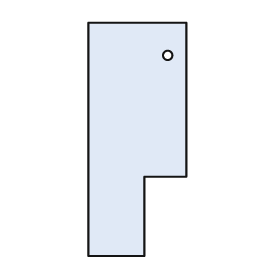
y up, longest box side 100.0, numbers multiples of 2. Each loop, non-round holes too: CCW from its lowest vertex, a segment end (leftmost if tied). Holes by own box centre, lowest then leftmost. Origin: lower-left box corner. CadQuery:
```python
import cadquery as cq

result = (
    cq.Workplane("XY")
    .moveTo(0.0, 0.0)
    .lineTo(24.0, 0.0)
    .lineTo(24.0, 34.0)
    .lineTo(42.0, 34.0)
    .lineTo(42.0, 100.0)
    .lineTo(0.0, 100.0)
    .close()
    .moveTo(34.0, 86.0)
    .circle(2.0)
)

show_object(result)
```